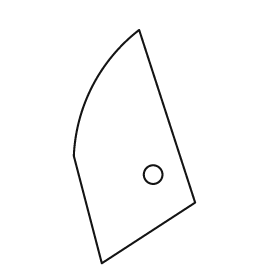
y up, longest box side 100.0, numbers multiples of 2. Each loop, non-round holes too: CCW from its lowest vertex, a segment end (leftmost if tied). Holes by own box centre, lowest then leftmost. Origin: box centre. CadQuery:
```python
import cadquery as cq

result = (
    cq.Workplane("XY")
    .moveTo(-14.0, -50.0)
    .lineTo(26.0, -24.0)
    .lineTo(2.0, 50.0)
    .threePointArc((-18.0, 26.0), (-26.0, -4.0))
    .close()
    .moveTo(8.0, -12.0)
    .circle(4.0)
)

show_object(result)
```